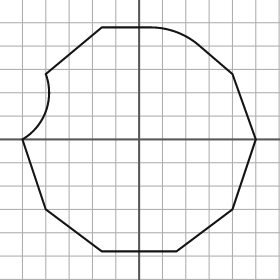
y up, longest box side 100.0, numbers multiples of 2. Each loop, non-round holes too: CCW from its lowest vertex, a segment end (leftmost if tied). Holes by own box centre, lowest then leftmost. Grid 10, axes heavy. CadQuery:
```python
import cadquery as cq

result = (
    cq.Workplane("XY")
    .moveTo(-16.0, -48.0)
    .lineTo(16.0, -48.0)
    .lineTo(40.0, -30.0)
    .lineTo(50.0, 0.0)
    .lineTo(40.0, 28.0)
    .lineTo(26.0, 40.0)
    .threePointArc((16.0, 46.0), (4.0, 48.0))
    .lineTo(-16.0, 48.0)
    .lineTo(-40.0, 28.0)
    .threePointArc((-40.0, 12.0), (-50.0, 0.0))
    .lineTo(-40.0, -30.0)
    .close()
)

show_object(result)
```